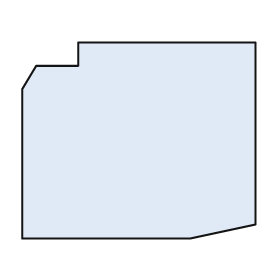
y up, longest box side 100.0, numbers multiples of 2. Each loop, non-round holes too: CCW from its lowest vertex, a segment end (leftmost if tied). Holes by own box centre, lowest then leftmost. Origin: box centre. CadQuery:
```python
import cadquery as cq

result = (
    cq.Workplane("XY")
    .moveTo(-50.0, -42.0)
    .lineTo(22.0, -42.0)
    .lineTo(50.0, -36.0)
    .lineTo(50.0, 42.0)
    .lineTo(-26.0, 42.0)
    .lineTo(-26.0, 32.0)
    .lineTo(-44.0, 32.0)
    .lineTo(-50.0, 22.0)
    .close()
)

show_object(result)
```